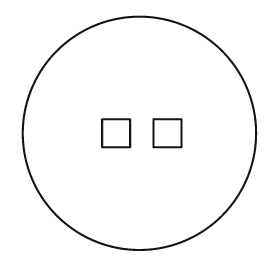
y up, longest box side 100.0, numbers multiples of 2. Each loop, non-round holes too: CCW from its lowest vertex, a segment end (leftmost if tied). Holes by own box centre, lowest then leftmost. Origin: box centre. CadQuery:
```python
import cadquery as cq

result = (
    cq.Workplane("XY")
    .moveTo(0.0, 0.0)
    .circle(50.0)
    .moveTo(-16.0, -6.0)
    .lineTo(-4.0, -6.0)
    .lineTo(-4.0, 6.0)
    .lineTo(-16.0, 6.0)
    .close()
    .moveTo(6.0, -6.0)
    .lineTo(18.0, -6.0)
    .lineTo(18.0, 6.0)
    .lineTo(6.0, 6.0)
    .close()
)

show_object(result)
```